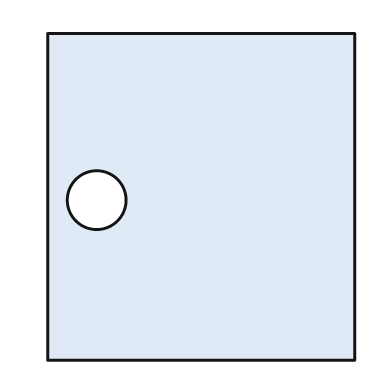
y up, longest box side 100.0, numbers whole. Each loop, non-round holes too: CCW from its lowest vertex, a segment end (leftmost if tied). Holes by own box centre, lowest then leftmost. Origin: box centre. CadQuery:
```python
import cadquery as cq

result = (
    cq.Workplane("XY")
    .moveTo(-47.0, -50.0)
    .lineTo(47.0, -50.0)
    .lineTo(47.0, 50.0)
    .lineTo(-47.0, 50.0)
    .close()
    .moveTo(-32.0, -1.0)
    .circle(9.0)
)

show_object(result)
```